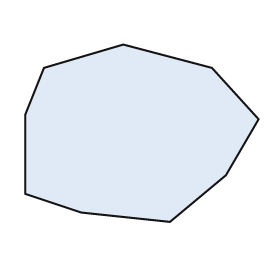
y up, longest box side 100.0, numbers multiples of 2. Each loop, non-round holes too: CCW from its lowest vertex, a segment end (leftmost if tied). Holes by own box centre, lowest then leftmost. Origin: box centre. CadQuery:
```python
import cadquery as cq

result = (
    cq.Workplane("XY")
    .moveTo(12.0, -38.0)
    .lineTo(36.0, -18.0)
    .lineTo(50.0, 6.0)
    .lineTo(30.0, 28.0)
    .lineTo(-8.0, 38.0)
    .lineTo(-42.0, 28.0)
    .lineTo(-50.0, 8.0)
    .lineTo(-50.0, -26.0)
    .lineTo(-26.0, -34.0)
    .close()
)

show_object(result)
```